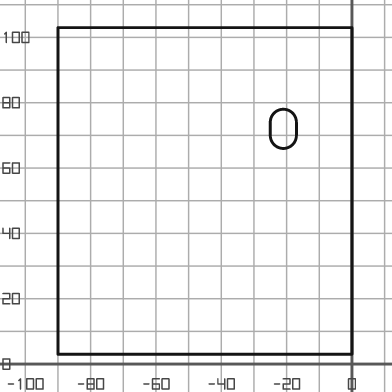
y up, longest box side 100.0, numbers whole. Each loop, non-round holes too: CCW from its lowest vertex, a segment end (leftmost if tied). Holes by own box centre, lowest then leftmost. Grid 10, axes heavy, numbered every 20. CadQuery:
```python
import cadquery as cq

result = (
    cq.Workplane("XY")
    .moveTo(-90.0, 3.0)
    .lineTo(0.0, 3.0)
    .lineTo(0.0, 103.0)
    .lineTo(-90.0, 103.0)
    .close()
    .moveTo(-25.0, 70.0)
    .threePointArc((-21.0, 66.0), (-17.0, 70.0))
    .lineTo(-17.0, 74.0)
    .threePointArc((-21.0, 78.0), (-25.0, 74.0))
    .close()
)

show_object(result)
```